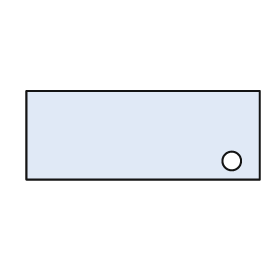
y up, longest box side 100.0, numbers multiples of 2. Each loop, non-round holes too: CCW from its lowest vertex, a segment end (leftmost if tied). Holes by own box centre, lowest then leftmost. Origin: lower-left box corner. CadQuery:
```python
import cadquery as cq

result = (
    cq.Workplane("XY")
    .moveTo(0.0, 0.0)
    .lineTo(100.0, 0.0)
    .lineTo(100.0, 38.0)
    .lineTo(0.0, 38.0)
    .close()
    .moveTo(88.0, 8.0)
    .circle(4.0)
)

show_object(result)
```